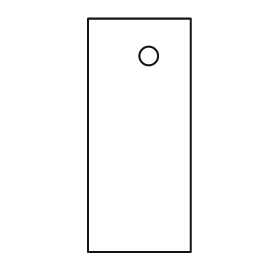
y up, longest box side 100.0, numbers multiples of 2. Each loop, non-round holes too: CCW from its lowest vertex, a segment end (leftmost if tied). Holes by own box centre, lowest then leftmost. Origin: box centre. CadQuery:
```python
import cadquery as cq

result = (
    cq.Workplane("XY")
    .moveTo(-22.0, -50.0)
    .lineTo(22.0, -50.0)
    .lineTo(22.0, 50.0)
    .lineTo(-22.0, 50.0)
    .close()
    .moveTo(4.0, 34.0)
    .circle(4.0)
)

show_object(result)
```